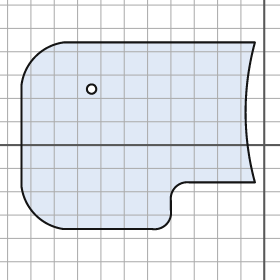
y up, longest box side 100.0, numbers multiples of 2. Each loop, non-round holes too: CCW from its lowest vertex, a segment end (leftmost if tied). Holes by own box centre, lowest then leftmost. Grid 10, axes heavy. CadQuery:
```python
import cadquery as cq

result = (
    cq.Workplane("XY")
    .moveTo(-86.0, -36.0)
    .lineTo(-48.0, -36.0)
    .threePointArc((-42.0, -34.0), (-40.0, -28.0))
    .lineTo(-40.0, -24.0)
    .threePointArc((-38.0, -18.0), (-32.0, -16.0))
    .lineTo(-4.0, -16.0)
    .threePointArc((-8.0, 14.0), (-4.0, 44.0))
    .lineTo(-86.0, 44.0)
    .threePointArc((-98.0, 38.0), (-104.0, 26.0))
    .lineTo(-104.0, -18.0)
    .threePointArc((-98.0, -30.0), (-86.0, -36.0))
    .close()
    .moveTo(-74.0, 24.0)
    .circle(2.0)
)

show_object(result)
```